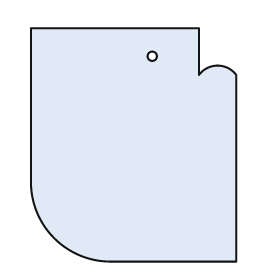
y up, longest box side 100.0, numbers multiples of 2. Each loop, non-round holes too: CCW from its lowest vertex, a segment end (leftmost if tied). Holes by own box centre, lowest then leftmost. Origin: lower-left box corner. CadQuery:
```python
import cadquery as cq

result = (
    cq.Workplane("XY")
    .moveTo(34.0, 0.0)
    .lineTo(88.0, 0.0)
    .lineTo(88.0, 80.0)
    .threePointArc((80.0, 84.0), (72.0, 80.0))
    .lineTo(72.0, 100.0)
    .lineTo(0.0, 100.0)
    .lineTo(0.0, 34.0)
    .threePointArc((10.0, 10.0), (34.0, 0.0))
    .close()
    .moveTo(52.0, 88.0)
    .circle(2.0)
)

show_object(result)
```